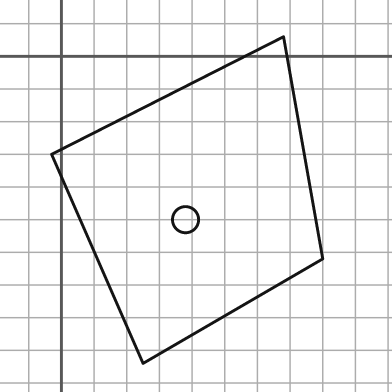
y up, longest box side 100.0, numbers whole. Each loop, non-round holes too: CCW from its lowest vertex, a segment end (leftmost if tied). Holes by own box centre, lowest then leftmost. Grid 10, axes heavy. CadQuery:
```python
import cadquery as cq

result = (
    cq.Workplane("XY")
    .moveTo(25.0, -94.0)
    .lineTo(80.0, -62.0)
    .lineTo(68.0, 6.0)
    .lineTo(-3.0, -30.0)
    .close()
    .moveTo(38.0, -50.0)
    .circle(4.0)
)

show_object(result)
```